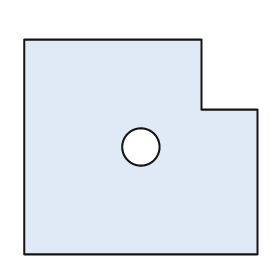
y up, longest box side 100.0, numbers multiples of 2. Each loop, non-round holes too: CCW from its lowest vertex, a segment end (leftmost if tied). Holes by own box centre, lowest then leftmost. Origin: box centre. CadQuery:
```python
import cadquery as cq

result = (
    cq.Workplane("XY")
    .moveTo(-50.0, -46.0)
    .lineTo(50.0, -46.0)
    .lineTo(50.0, 16.0)
    .lineTo(26.0, 16.0)
    .lineTo(26.0, 46.0)
    .lineTo(-50.0, 46.0)
    .close()
    .moveTo(0.0, 0.0)
    .circle(8.0)
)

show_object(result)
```